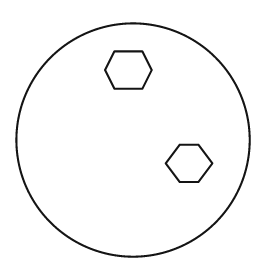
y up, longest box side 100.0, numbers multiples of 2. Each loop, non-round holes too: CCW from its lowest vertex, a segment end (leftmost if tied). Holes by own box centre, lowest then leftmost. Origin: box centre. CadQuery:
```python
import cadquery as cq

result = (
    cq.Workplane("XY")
    .moveTo(0.0, 0.0)
    .circle(50.0)
    .moveTo(20.0, -18.0)
    .lineTo(28.0, -18.0)
    .lineTo(34.0, -10.0)
    .lineTo(28.0, -2.0)
    .lineTo(20.0, -2.0)
    .lineTo(14.0, -10.0)
    .close()
    .moveTo(-8.0, 22.0)
    .lineTo(4.0, 22.0)
    .lineTo(8.0, 30.0)
    .lineTo(4.0, 38.0)
    .lineTo(-8.0, 38.0)
    .lineTo(-12.0, 30.0)
    .close()
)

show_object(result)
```